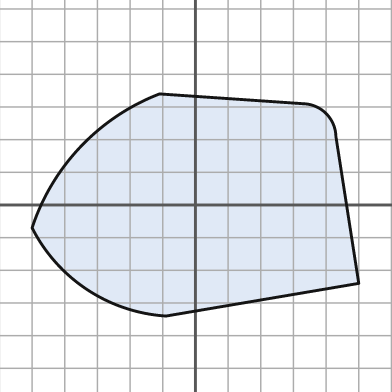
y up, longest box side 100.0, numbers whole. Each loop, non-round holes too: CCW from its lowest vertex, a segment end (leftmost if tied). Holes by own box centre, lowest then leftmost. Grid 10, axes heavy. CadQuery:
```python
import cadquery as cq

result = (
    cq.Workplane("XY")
    .moveTo(-9.0, -34.0)
    .lineTo(50.0, -24.0)
    .lineTo(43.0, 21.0)
    .threePointArc((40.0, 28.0), (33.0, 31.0))
    .lineTo(-11.0, 34.0)
    .threePointArc((-35.0, 18.0), (-50.0, -7.0))
    .threePointArc((-33.0, -26.0), (-9.0, -34.0))
    .close()
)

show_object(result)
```